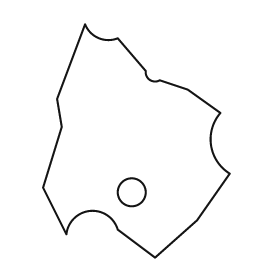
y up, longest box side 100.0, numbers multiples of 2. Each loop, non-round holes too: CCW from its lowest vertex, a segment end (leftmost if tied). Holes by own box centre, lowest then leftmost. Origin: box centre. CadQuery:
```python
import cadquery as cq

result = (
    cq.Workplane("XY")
    .moveTo(8.0, -50.0)
    .lineTo(26.0, -34.0)
    .lineTo(40.0, -14.0)
    .threePointArc((32.0, -2.0), (36.0, 12.0))
    .lineTo(22.0, 22.0)
    .lineTo(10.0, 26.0)
    .threePointArc((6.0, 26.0), (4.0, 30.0))
    .lineTo(-8.0, 44.0)
    .threePointArc((-16.0, 44.0), (-22.0, 50.0))
    .lineTo(-34.0, 18.0)
    .lineTo(-32.0, 6.0)
    .lineTo(-40.0, -20.0)
    .lineTo(-30.0, -40.0)
    .threePointArc((-20.0, -30.0), (-8.0, -38.0))
    .close()
    .moveTo(-2.0, -22.0)
    .circle(6.0)
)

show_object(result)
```